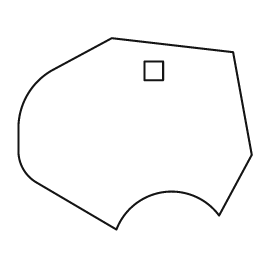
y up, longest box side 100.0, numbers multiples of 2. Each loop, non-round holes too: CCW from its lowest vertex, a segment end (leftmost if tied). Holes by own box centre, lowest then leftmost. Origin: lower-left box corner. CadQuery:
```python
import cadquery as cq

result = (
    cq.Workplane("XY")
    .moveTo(42.0, 0.0)
    .threePointArc((62.0, 16.0), (86.0, 6.0))
    .lineTo(100.0, 32.0)
    .lineTo(92.0, 76.0)
    .lineTo(40.0, 82.0)
    .lineTo(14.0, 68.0)
    .threePointArc((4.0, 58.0), (0.0, 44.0))
    .lineTo(0.0, 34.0)
    .threePointArc((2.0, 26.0), (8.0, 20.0))
    .close()
    .moveTo(54.0, 64.0)
    .lineTo(62.0, 64.0)
    .lineTo(62.0, 72.0)
    .lineTo(54.0, 72.0)
    .close()
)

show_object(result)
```